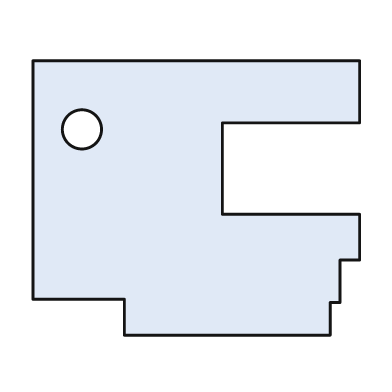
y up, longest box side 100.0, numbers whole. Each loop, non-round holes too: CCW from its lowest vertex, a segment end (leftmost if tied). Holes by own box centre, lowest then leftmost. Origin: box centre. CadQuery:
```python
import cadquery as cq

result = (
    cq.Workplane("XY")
    .moveTo(-22.0, -42.0)
    .lineTo(41.0, -42.0)
    .lineTo(41.0, -32.0)
    .lineTo(44.0, -32.0)
    .lineTo(44.0, -19.0)
    .lineTo(50.0, -19.0)
    .lineTo(50.0, -5.0)
    .lineTo(8.0, -5.0)
    .lineTo(8.0, 23.0)
    .lineTo(50.0, 23.0)
    .lineTo(50.0, 42.0)
    .lineTo(-50.0, 42.0)
    .lineTo(-50.0, -31.0)
    .lineTo(-22.0, -31.0)
    .close()
    .moveTo(-35.0, 21.0)
    .circle(6.0)
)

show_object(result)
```